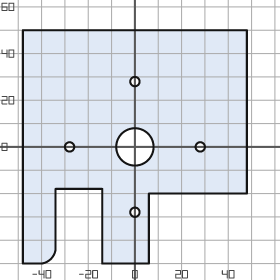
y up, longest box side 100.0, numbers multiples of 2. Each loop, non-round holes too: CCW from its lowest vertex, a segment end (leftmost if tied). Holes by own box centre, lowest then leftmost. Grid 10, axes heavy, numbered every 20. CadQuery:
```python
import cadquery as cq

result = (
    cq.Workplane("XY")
    .moveTo(-48.0, -50.0)
    .lineTo(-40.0, -50.0)
    .threePointArc((-36.0, -48.0), (-34.0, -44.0))
    .lineTo(-34.0, -18.0)
    .lineTo(-14.0, -18.0)
    .lineTo(-14.0, -50.0)
    .lineTo(6.0, -50.0)
    .lineTo(6.0, -20.0)
    .lineTo(48.0, -20.0)
    .lineTo(48.0, 50.0)
    .lineTo(-48.0, 50.0)
    .close()
    .moveTo(0.0, -28.0)
    .circle(2.0)
    .moveTo(-28.0, 0.0)
    .circle(2.0)
    .moveTo(0.0, 0.0)
    .circle(8.0)
    .moveTo(28.0, 0.0)
    .circle(2.0)
    .moveTo(0.0, 28.0)
    .circle(2.0)
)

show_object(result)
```